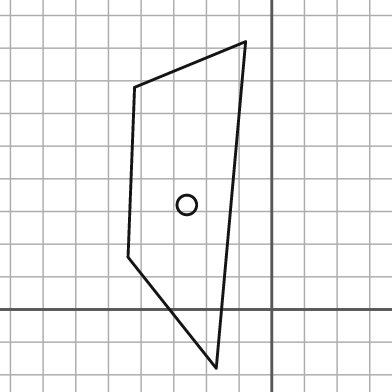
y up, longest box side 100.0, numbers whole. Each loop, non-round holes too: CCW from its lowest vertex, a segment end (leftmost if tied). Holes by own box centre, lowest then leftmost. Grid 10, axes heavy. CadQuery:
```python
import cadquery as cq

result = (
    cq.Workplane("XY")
    .moveTo(-17.0, -18.0)
    .lineTo(-8.0, 82.0)
    .lineTo(-42.0, 68.0)
    .lineTo(-44.0, 16.0)
    .close()
    .moveTo(-26.0, 32.0)
    .circle(3.0)
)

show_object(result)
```